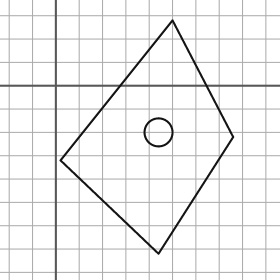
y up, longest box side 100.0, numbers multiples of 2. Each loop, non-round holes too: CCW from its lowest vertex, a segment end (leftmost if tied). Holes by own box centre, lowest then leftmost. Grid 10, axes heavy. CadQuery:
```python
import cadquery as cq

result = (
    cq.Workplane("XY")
    .moveTo(44.0, -72.0)
    .lineTo(76.0, -22.0)
    .lineTo(50.0, 28.0)
    .lineTo(2.0, -32.0)
    .close()
    .moveTo(44.0, -20.0)
    .circle(6.0)
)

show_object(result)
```